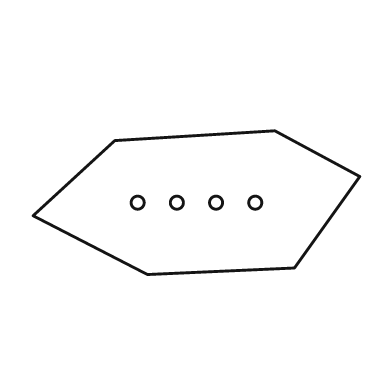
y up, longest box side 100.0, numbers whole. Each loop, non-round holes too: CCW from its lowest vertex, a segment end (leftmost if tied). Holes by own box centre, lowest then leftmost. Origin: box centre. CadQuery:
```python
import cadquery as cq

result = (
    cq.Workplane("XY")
    .moveTo(-15.0, -22.0)
    .lineTo(30.0, -20.0)
    .lineTo(50.0, 8.0)
    .lineTo(24.0, 22.0)
    .lineTo(-25.0, 19.0)
    .lineTo(-50.0, -4.0)
    .close()
    .moveTo(-18.0, 0.0)
    .circle(2.0)
    .moveTo(-6.0, 0.0)
    .circle(2.0)
    .moveTo(6.0, 0.0)
    .circle(2.0)
    .moveTo(18.0, 0.0)
    .circle(2.0)
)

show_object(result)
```